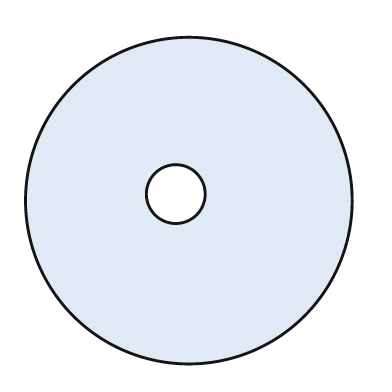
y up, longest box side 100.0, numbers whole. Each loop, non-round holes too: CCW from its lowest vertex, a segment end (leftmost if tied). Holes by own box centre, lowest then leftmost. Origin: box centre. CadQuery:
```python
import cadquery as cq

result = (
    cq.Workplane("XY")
    .moveTo(0.0, 0.0)
    .circle(50.0)
    .moveTo(-4.0, 2.0)
    .circle(9.0)
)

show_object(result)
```